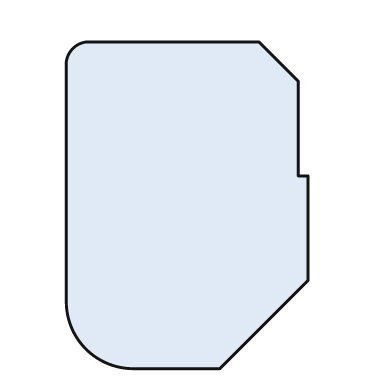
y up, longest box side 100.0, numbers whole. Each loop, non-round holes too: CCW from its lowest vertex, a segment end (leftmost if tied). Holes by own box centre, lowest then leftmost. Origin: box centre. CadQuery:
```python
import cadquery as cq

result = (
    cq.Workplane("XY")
    .moveTo(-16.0, -50.0)
    .lineTo(10.0, -50.0)
    .lineTo(37.0, -23.0)
    .lineTo(37.0, 9.0)
    .lineTo(34.0, 9.0)
    .lineTo(34.0, 38.0)
    .lineTo(22.0, 50.0)
    .lineTo(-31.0, 50.0)
    .threePointArc((-35.0, 48.0), (-37.0, 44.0))
    .lineTo(-37.0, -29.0)
    .threePointArc((-31.0, -44.0), (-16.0, -50.0))
    .close()
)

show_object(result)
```